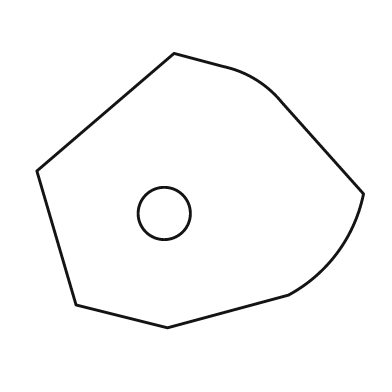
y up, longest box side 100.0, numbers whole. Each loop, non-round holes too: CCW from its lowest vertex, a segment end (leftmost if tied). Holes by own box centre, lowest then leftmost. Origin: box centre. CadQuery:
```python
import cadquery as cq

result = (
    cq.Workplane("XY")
    .moveTo(-10.0, -42.0)
    .lineTo(27.0, -32.0)
    .threePointArc((42.0, -19.0), (50.0, -1.0))
    .lineTo(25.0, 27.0)
    .threePointArc((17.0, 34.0), (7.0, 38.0))
    .lineTo(-8.0, 42.0)
    .lineTo(-50.0, 6.0)
    .lineTo(-38.0, -35.0)
    .close()
    .moveTo(-11.0, -7.0)
    .circle(8.0)
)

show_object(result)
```